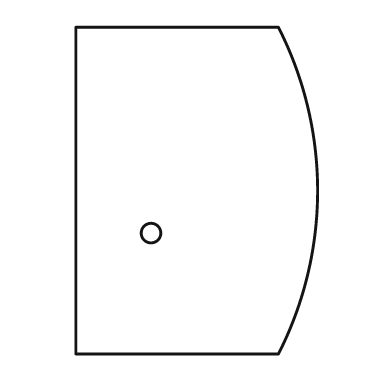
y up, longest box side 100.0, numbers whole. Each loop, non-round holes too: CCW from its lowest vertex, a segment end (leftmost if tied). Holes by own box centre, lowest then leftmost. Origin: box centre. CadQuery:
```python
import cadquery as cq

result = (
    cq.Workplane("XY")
    .moveTo(-37.0, -50.0)
    .lineTo(25.0, -50.0)
    .threePointArc((37.0, 0.0), (25.0, 50.0))
    .lineTo(-37.0, 50.0)
    .close()
    .moveTo(-14.0, -13.0)
    .circle(3.0)
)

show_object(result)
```